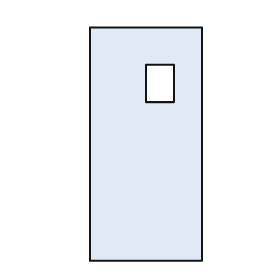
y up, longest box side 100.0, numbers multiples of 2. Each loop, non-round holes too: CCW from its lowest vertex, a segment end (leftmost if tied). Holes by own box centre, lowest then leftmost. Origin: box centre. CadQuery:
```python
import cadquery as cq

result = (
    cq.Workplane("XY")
    .moveTo(-24.0, -50.0)
    .lineTo(24.0, -50.0)
    .lineTo(24.0, 50.0)
    .lineTo(-24.0, 50.0)
    .close()
    .moveTo(0.0, 18.0)
    .lineTo(12.0, 18.0)
    .lineTo(12.0, 34.0)
    .lineTo(0.0, 34.0)
    .close()
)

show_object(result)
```